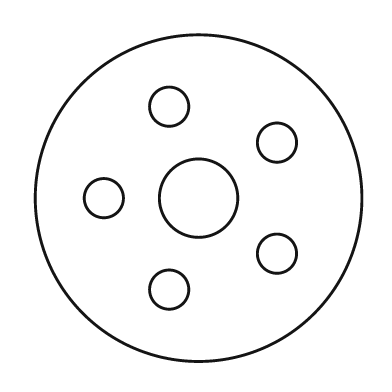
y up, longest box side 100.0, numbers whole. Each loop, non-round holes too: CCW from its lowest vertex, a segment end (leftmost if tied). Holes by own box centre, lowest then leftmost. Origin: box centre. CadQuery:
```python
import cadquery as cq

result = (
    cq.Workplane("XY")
    .moveTo(0.0, 0.0)
    .circle(50.0)
    .moveTo(-9.0, -28.0)
    .circle(6.0)
    .moveTo(24.0, -17.0)
    .circle(6.0)
    .moveTo(-29.0, 0.0)
    .circle(6.0)
    .moveTo(0.0, 0.0)
    .circle(12.0)
    .moveTo(24.0, 17.0)
    .circle(6.0)
    .moveTo(-9.0, 28.0)
    .circle(6.0)
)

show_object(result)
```